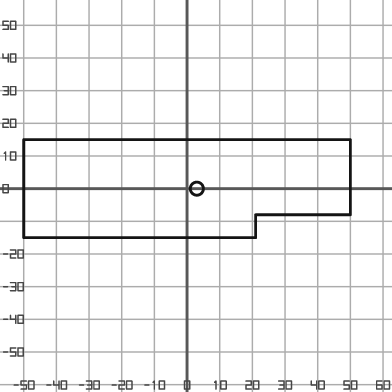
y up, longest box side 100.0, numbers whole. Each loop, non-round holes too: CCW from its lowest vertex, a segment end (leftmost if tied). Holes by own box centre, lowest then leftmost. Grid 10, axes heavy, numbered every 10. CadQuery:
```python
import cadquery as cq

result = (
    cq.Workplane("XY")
    .moveTo(-50.0, -15.0)
    .lineTo(21.0, -15.0)
    .lineTo(21.0, -8.0)
    .lineTo(50.0, -8.0)
    .lineTo(50.0, 15.0)
    .lineTo(-50.0, 15.0)
    .close()
    .moveTo(3.0, 0.0)
    .circle(2.0)
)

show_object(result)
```